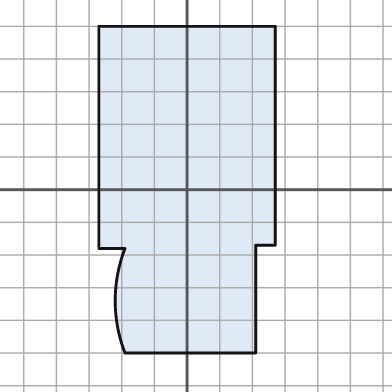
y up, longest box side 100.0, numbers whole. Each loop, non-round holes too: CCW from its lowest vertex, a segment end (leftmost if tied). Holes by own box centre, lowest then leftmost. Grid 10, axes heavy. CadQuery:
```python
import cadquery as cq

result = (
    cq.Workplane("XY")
    .moveTo(-19.0, -50.0)
    .lineTo(21.0, -50.0)
    .lineTo(21.0, -17.0)
    .lineTo(27.0, -17.0)
    .lineTo(27.0, 50.0)
    .lineTo(-27.0, 50.0)
    .lineTo(-27.0, -18.0)
    .lineTo(-19.0, -18.0)
    .threePointArc((-22.0, -34.0), (-19.0, -50.0))
    .close()
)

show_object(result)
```